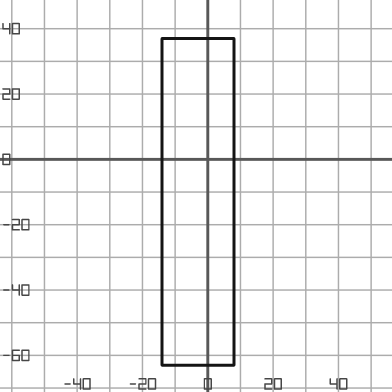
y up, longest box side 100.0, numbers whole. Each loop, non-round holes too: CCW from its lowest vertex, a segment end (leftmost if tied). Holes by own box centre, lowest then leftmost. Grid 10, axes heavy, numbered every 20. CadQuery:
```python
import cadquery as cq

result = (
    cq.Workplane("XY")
    .moveTo(-14.0, -63.0)
    .lineTo(8.0, -63.0)
    .lineTo(8.0, 37.0)
    .lineTo(-14.0, 37.0)
    .close()
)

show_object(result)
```